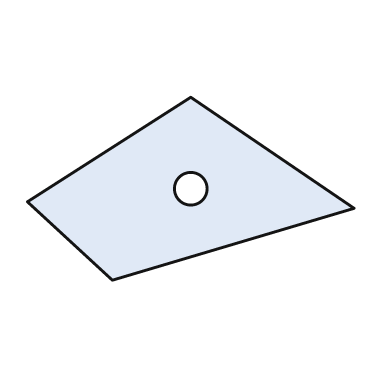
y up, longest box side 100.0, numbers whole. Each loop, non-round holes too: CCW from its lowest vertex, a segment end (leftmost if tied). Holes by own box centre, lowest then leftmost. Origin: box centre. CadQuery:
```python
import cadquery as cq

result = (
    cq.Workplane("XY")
    .moveTo(-24.0, -28.0)
    .lineTo(50.0, -6.0)
    .lineTo(0.0, 28.0)
    .lineTo(-50.0, -4.0)
    .close()
    .moveTo(0.0, 0.0)
    .circle(5.0)
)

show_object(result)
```